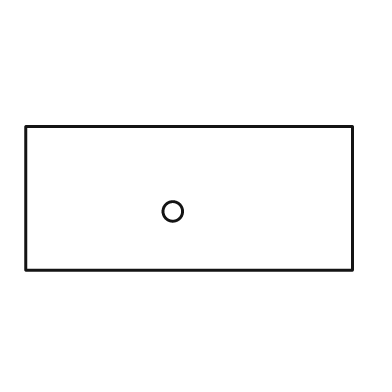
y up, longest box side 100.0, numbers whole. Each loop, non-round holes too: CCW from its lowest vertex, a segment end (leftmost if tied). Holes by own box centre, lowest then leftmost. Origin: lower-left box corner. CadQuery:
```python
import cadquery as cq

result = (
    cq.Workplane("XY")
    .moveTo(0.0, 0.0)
    .lineTo(100.0, 0.0)
    .lineTo(100.0, 44.0)
    .lineTo(0.0, 44.0)
    .close()
    .moveTo(45.0, 18.0)
    .circle(3.0)
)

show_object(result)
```